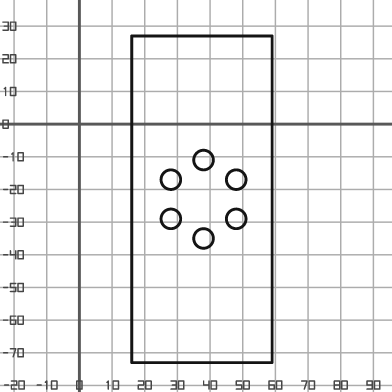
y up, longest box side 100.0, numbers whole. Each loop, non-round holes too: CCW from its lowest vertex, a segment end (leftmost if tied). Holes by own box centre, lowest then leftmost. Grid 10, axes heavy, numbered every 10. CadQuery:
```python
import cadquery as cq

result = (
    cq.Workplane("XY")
    .moveTo(16.0, -73.0)
    .lineTo(59.0, -73.0)
    .lineTo(59.0, 27.0)
    .lineTo(16.0, 27.0)
    .close()
    .moveTo(38.0, -35.0)
    .circle(3.0)
    .moveTo(28.0, -29.0)
    .circle(3.0)
    .moveTo(48.0, -29.0)
    .circle(3.0)
    .moveTo(28.0, -17.0)
    .circle(3.0)
    .moveTo(48.0, -17.0)
    .circle(3.0)
    .moveTo(38.0, -11.0)
    .circle(3.0)
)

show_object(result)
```